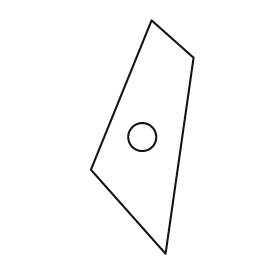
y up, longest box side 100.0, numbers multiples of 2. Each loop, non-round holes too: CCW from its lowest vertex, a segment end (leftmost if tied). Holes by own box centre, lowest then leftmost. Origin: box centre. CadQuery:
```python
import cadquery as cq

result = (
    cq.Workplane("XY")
    .moveTo(10.0, -50.0)
    .lineTo(22.0, 34.0)
    .lineTo(4.0, 50.0)
    .lineTo(-22.0, -14.0)
    .close()
    .moveTo(0.0, 0.0)
    .circle(6.0)
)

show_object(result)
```